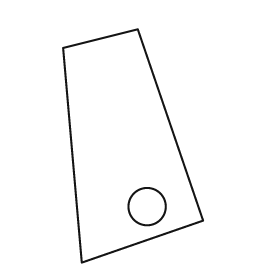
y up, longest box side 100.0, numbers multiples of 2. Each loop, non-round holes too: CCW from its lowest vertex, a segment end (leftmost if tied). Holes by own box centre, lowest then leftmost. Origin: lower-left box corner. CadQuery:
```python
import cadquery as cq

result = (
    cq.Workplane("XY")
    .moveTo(8.0, 0.0)
    .lineTo(60.0, 18.0)
    .lineTo(32.0, 100.0)
    .lineTo(0.0, 92.0)
    .close()
    .moveTo(36.0, 24.0)
    .circle(8.0)
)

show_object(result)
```